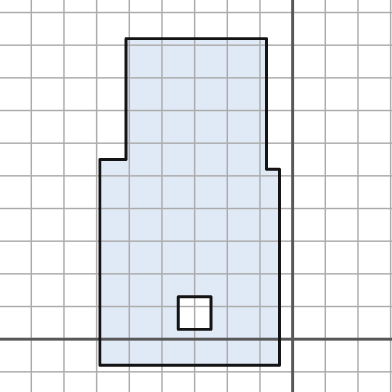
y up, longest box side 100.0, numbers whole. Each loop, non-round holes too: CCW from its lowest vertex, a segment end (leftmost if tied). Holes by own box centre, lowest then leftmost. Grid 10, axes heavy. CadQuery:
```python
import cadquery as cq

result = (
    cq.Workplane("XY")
    .moveTo(-59.0, -8.0)
    .lineTo(-4.0, -8.0)
    .lineTo(-4.0, 52.0)
    .lineTo(-8.0, 52.0)
    .lineTo(-8.0, 92.0)
    .lineTo(-51.0, 92.0)
    .lineTo(-51.0, 55.0)
    .lineTo(-59.0, 55.0)
    .close()
    .moveTo(-35.0, 3.0)
    .lineTo(-25.0, 3.0)
    .lineTo(-25.0, 13.0)
    .lineTo(-35.0, 13.0)
    .close()
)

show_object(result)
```